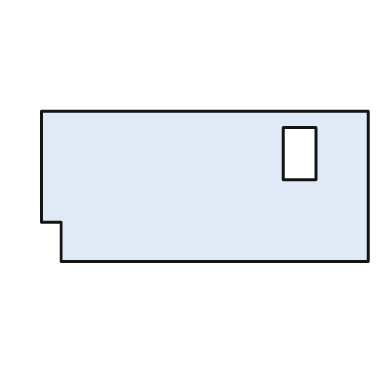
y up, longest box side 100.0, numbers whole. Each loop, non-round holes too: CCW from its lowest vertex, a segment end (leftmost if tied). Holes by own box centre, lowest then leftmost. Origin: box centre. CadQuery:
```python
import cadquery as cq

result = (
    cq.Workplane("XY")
    .moveTo(-44.0, -23.0)
    .lineTo(50.0, -23.0)
    .lineTo(50.0, 23.0)
    .lineTo(-50.0, 23.0)
    .lineTo(-50.0, -11.0)
    .lineTo(-44.0, -11.0)
    .close()
    .moveTo(24.0, 2.0)
    .lineTo(34.0, 2.0)
    .lineTo(34.0, 18.0)
    .lineTo(24.0, 18.0)
    .close()
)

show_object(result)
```